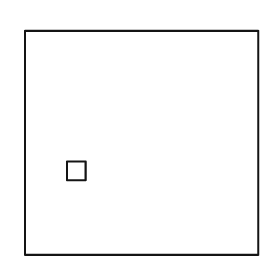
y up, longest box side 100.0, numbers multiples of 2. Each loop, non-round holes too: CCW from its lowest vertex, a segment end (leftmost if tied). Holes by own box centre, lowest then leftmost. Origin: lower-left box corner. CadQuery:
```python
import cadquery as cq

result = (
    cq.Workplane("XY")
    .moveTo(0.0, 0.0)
    .lineTo(100.0, 0.0)
    .lineTo(100.0, 96.0)
    .lineTo(0.0, 96.0)
    .close()
    .moveTo(18.0, 32.0)
    .lineTo(26.0, 32.0)
    .lineTo(26.0, 40.0)
    .lineTo(18.0, 40.0)
    .close()
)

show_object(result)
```